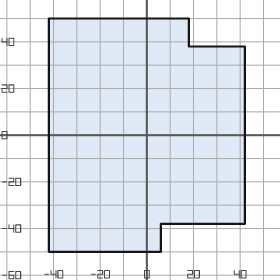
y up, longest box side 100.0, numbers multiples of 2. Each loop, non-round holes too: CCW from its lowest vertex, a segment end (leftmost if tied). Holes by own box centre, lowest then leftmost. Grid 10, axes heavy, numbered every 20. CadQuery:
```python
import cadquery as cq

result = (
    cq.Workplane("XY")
    .moveTo(-42.0, -50.0)
    .lineTo(6.0, -50.0)
    .lineTo(6.0, -38.0)
    .lineTo(42.0, -38.0)
    .lineTo(42.0, 38.0)
    .lineTo(18.0, 38.0)
    .lineTo(18.0, 50.0)
    .lineTo(-42.0, 50.0)
    .close()
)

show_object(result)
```